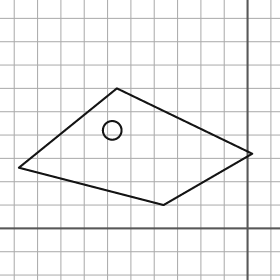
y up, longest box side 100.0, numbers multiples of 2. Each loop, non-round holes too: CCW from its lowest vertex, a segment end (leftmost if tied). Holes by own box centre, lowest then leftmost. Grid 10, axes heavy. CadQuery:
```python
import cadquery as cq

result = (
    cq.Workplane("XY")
    .moveTo(-36.0, 10.0)
    .lineTo(2.0, 32.0)
    .lineTo(-56.0, 60.0)
    .lineTo(-98.0, 26.0)
    .close()
    .moveTo(-58.0, 42.0)
    .circle(4.0)
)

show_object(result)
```